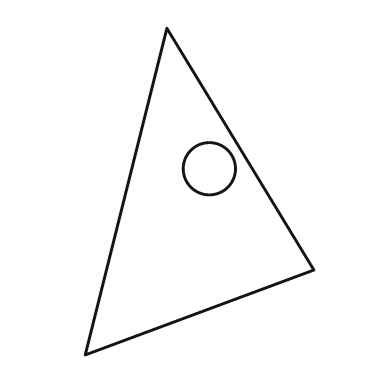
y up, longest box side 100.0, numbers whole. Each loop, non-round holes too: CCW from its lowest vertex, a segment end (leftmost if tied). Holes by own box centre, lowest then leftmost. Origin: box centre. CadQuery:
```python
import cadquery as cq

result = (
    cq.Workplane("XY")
    .moveTo(-35.0, -50.0)
    .lineTo(35.0, -24.0)
    .lineTo(-10.0, 50.0)
    .close()
    .moveTo(3.0, 7.0)
    .circle(8.0)
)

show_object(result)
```